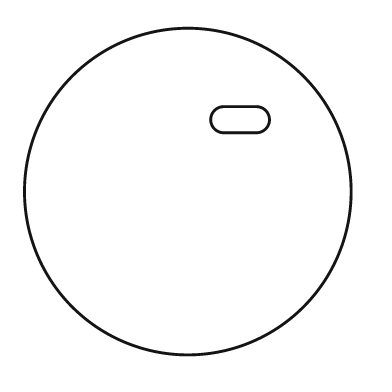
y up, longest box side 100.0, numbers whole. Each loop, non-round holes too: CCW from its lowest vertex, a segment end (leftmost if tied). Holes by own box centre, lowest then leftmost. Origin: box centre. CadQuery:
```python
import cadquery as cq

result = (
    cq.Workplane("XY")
    .moveTo(0.0, 0.0)
    .circle(50.0)
    .moveTo(11.0, 18.0)
    .lineTo(21.0, 18.0)
    .threePointArc((25.0, 22.0), (21.0, 26.0))
    .lineTo(11.0, 26.0)
    .threePointArc((7.0, 22.0), (11.0, 18.0))
    .close()
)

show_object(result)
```